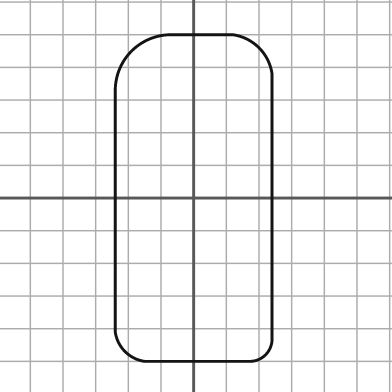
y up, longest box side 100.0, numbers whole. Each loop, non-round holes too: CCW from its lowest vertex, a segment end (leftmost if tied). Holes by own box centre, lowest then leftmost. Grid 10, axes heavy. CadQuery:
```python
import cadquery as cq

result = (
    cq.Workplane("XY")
    .moveTo(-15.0, -50.0)
    .lineTo(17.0, -50.0)
    .threePointArc((22.0, -48.0), (24.0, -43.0))
    .lineTo(24.0, 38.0)
    .threePointArc((20.0, 46.0), (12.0, 50.0))
    .lineTo(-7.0, 50.0)
    .threePointArc((-19.0, 45.0), (-24.0, 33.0))
    .lineTo(-24.0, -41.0)
    .threePointArc((-21.0, -47.0), (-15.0, -50.0))
    .close()
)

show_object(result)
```